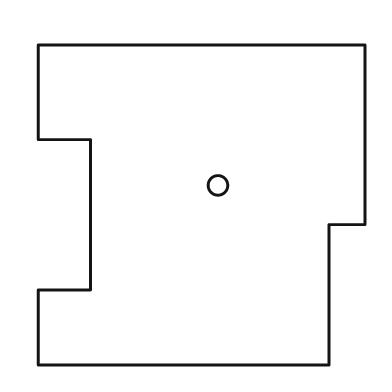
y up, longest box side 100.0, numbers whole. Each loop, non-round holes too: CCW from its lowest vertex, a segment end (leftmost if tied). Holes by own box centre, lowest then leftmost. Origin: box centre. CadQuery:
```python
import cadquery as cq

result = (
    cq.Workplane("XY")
    .moveTo(-50.0, -49.0)
    .lineTo(39.0, -49.0)
    .lineTo(39.0, -6.0)
    .lineTo(50.0, -6.0)
    .lineTo(50.0, 49.0)
    .lineTo(-50.0, 49.0)
    .lineTo(-50.0, 20.0)
    .lineTo(-34.0, 20.0)
    .lineTo(-34.0, -26.0)
    .lineTo(-50.0, -26.0)
    .close()
    .moveTo(5.0, 6.0)
    .circle(3.0)
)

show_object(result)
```